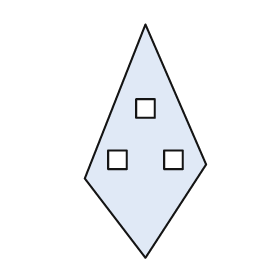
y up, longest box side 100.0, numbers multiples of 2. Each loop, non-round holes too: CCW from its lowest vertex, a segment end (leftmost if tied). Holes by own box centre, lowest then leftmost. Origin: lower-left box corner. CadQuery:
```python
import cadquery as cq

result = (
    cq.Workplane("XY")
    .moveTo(26.0, 0.0)
    .lineTo(52.0, 40.0)
    .lineTo(26.0, 100.0)
    .lineTo(0.0, 34.0)
    .close()
    .moveTo(10.0, 38.0)
    .lineTo(18.0, 38.0)
    .lineTo(18.0, 46.0)
    .lineTo(10.0, 46.0)
    .close()
    .moveTo(34.0, 38.0)
    .lineTo(42.0, 38.0)
    .lineTo(42.0, 46.0)
    .lineTo(34.0, 46.0)
    .close()
    .moveTo(22.0, 60.0)
    .lineTo(30.0, 60.0)
    .lineTo(30.0, 68.0)
    .lineTo(22.0, 68.0)
    .close()
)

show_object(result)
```